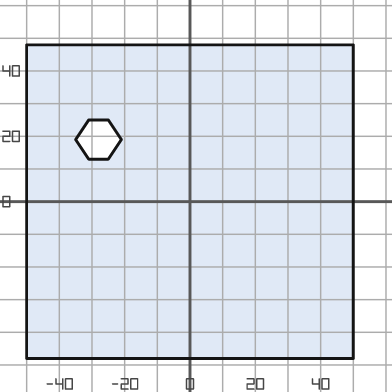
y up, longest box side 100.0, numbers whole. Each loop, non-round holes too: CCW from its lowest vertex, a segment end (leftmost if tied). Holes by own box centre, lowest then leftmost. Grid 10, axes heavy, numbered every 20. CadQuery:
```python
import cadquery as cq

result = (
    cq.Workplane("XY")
    .moveTo(-50.0, -48.0)
    .lineTo(50.0, -48.0)
    .lineTo(50.0, 48.0)
    .lineTo(-50.0, 48.0)
    .close()
    .moveTo(-31.0, 13.0)
    .lineTo(-25.0, 13.0)
    .lineTo(-21.0, 19.0)
    .lineTo(-25.0, 25.0)
    .lineTo(-31.0, 25.0)
    .lineTo(-35.0, 19.0)
    .close()
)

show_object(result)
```